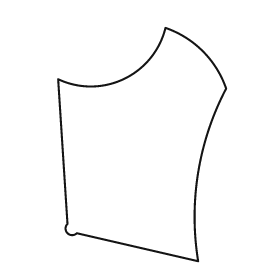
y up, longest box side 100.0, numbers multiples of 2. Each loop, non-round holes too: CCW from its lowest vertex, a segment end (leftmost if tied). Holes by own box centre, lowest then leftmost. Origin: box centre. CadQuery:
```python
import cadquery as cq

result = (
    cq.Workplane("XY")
    .moveTo(24.0, -50.0)
    .threePointArc((24.0, -12.0), (36.0, 24.0))
    .threePointArc((26.0, 40.0), (10.0, 50.0))
    .threePointArc((-8.0, 28.0), (-36.0, 28.0))
    .lineTo(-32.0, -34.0)
    .threePointArc((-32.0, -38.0), (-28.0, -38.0))
    .close()
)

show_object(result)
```